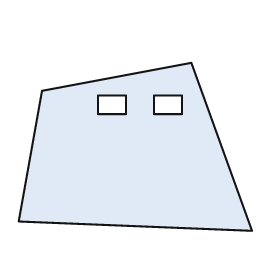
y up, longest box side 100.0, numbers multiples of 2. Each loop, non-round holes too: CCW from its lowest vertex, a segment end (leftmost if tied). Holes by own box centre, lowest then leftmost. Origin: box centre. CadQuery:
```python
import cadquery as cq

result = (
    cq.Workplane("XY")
    .moveTo(50.0, -36.0)
    .lineTo(24.0, 36.0)
    .lineTo(-40.0, 24.0)
    .lineTo(-50.0, -32.0)
    .close()
    .moveTo(-16.0, 14.0)
    .lineTo(-4.0, 14.0)
    .lineTo(-4.0, 22.0)
    .lineTo(-16.0, 22.0)
    .close()
    .moveTo(8.0, 14.0)
    .lineTo(20.0, 14.0)
    .lineTo(20.0, 22.0)
    .lineTo(8.0, 22.0)
    .close()
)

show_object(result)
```